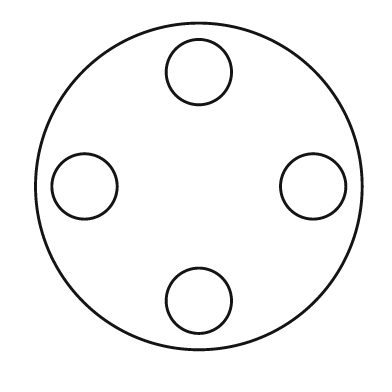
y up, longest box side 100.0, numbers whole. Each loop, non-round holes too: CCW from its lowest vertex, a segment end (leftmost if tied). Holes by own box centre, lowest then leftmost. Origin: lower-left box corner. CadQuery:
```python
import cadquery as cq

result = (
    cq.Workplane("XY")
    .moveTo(50.0, 50.0)
    .circle(50.0)
    .moveTo(50.0, 15.0)
    .circle(10.0)
    .moveTo(15.0, 50.0)
    .circle(10.0)
    .moveTo(85.0, 50.0)
    .circle(10.0)
    .moveTo(50.0, 85.0)
    .circle(10.0)
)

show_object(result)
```